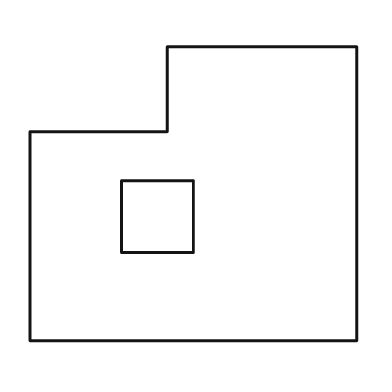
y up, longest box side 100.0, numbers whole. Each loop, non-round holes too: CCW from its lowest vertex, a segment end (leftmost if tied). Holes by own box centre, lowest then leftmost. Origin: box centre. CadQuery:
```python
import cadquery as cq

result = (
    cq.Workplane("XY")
    .moveTo(-50.0, -45.0)
    .lineTo(50.0, -45.0)
    .lineTo(50.0, 45.0)
    .lineTo(-8.0, 45.0)
    .lineTo(-8.0, 19.0)
    .lineTo(-50.0, 19.0)
    .close()
    .moveTo(-22.0, -18.0)
    .lineTo(0.0, -18.0)
    .lineTo(0.0, 4.0)
    .lineTo(-22.0, 4.0)
    .close()
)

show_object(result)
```